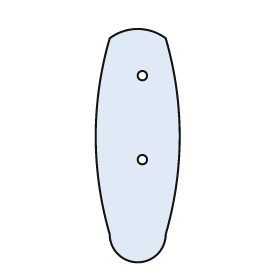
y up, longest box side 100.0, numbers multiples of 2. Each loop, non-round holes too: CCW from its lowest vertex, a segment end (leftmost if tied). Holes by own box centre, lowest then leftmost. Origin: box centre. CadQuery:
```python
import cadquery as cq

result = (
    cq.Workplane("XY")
    .moveTo(-12.0, -38.0)
    .threePointArc((0.0, -50.0), (12.0, -38.0))
    .threePointArc((18.0, 4.0), (12.0, 46.0))
    .threePointArc((0.0, 50.0), (-12.0, 46.0))
    .threePointArc((-18.0, 4.0), (-12.0, -38.0))
    .close()
    .moveTo(2.0, -6.0)
    .circle(2.0)
    .moveTo(2.0, 30.0)
    .circle(2.0)
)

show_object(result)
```